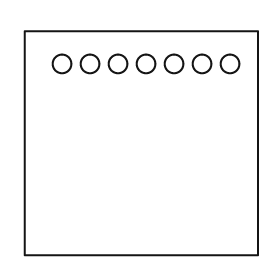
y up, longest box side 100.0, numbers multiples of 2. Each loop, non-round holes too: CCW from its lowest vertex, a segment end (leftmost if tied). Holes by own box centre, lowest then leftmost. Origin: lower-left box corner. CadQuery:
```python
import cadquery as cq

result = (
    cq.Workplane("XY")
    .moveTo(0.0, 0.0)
    .lineTo(100.0, 0.0)
    .lineTo(100.0, 96.0)
    .lineTo(0.0, 96.0)
    .close()
    .moveTo(16.0, 82.0)
    .circle(4.0)
    .moveTo(28.0, 82.0)
    .circle(4.0)
    .moveTo(40.0, 82.0)
    .circle(4.0)
    .moveTo(52.0, 82.0)
    .circle(4.0)
    .moveTo(64.0, 82.0)
    .circle(4.0)
    .moveTo(76.0, 82.0)
    .circle(4.0)
    .moveTo(88.0, 82.0)
    .circle(4.0)
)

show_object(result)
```